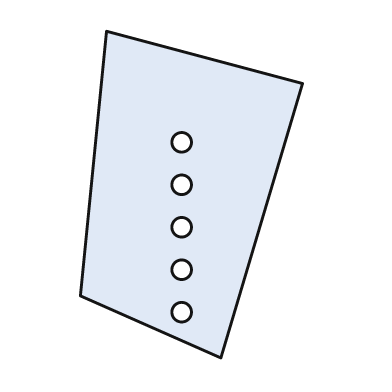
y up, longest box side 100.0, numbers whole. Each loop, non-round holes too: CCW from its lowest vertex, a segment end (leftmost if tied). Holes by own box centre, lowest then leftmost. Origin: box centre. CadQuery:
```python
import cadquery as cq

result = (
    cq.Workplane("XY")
    .moveTo(9.0, -50.0)
    .lineTo(34.0, 34.0)
    .lineTo(-26.0, 50.0)
    .lineTo(-34.0, -31.0)
    .close()
    .moveTo(-3.0, -36.0)
    .circle(3.0)
    .moveTo(-3.0, -23.0)
    .circle(3.0)
    .moveTo(-3.0, -10.0)
    .circle(3.0)
    .moveTo(-3.0, 3.0)
    .circle(3.0)
    .moveTo(-3.0, 16.0)
    .circle(3.0)
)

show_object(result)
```